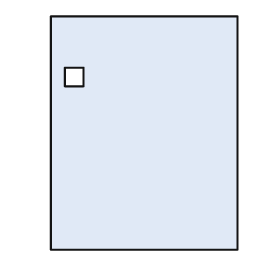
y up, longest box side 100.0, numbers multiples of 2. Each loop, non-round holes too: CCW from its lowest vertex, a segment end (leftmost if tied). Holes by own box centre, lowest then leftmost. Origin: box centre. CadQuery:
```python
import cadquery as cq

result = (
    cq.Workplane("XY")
    .moveTo(-40.0, -50.0)
    .lineTo(40.0, -50.0)
    .lineTo(40.0, 50.0)
    .lineTo(-40.0, 50.0)
    .close()
    .moveTo(-34.0, 20.0)
    .lineTo(-26.0, 20.0)
    .lineTo(-26.0, 28.0)
    .lineTo(-34.0, 28.0)
    .close()
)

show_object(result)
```